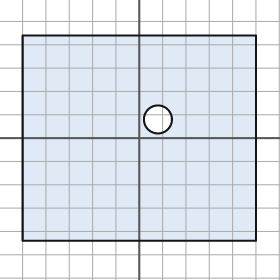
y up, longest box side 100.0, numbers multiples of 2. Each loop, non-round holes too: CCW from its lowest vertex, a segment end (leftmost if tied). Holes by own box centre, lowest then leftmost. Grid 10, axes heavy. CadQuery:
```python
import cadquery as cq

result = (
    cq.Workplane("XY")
    .moveTo(-50.0, -44.0)
    .lineTo(50.0, -44.0)
    .lineTo(50.0, 44.0)
    .lineTo(-50.0, 44.0)
    .close()
    .moveTo(8.0, 8.0)
    .circle(6.0)
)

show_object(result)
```